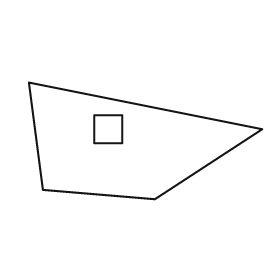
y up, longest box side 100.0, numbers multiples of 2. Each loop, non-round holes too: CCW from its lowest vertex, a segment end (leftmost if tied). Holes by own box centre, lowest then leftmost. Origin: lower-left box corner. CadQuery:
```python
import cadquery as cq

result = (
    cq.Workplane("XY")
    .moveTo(54.0, 0.0)
    .lineTo(100.0, 30.0)
    .lineTo(0.0, 50.0)
    .lineTo(6.0, 4.0)
    .close()
    .moveTo(28.0, 24.0)
    .lineTo(40.0, 24.0)
    .lineTo(40.0, 36.0)
    .lineTo(28.0, 36.0)
    .close()
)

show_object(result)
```